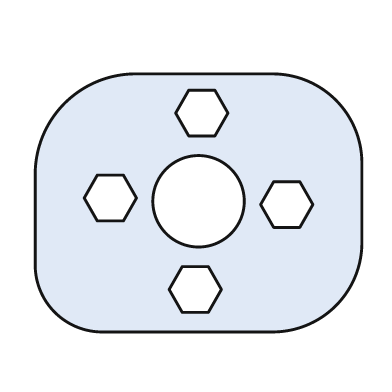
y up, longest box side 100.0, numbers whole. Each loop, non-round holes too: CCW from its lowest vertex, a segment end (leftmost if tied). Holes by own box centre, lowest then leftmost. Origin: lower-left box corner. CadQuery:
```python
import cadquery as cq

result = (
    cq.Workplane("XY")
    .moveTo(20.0, 0.0)
    .lineTo(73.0, 0.0)
    .threePointArc((92.0, 8.0), (100.0, 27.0))
    .lineTo(100.0, 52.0)
    .threePointArc((92.0, 71.0), (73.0, 79.0))
    .lineTo(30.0, 79.0)
    .threePointArc((9.0, 70.0), (0.0, 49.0))
    .lineTo(0.0, 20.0)
    .threePointArc((6.0, 6.0), (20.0, 0.0))
    .close()
    .moveTo(45.0, 6.0)
    .lineTo(53.0, 6.0)
    .lineTo(57.0, 13.0)
    .lineTo(53.0, 20.0)
    .lineTo(45.0, 20.0)
    .lineTo(41.0, 13.0)
    .close()
    .moveTo(73.0, 32.0)
    .lineTo(81.0, 32.0)
    .lineTo(85.0, 39.0)
    .lineTo(81.0, 46.0)
    .lineTo(73.0, 46.0)
    .lineTo(69.0, 39.0)
    .close()
    .moveTo(50.0, 40.0)
    .circle(14.0)
    .moveTo(19.0, 34.0)
    .lineTo(27.0, 34.0)
    .lineTo(31.0, 41.0)
    .lineTo(27.0, 48.0)
    .lineTo(19.0, 48.0)
    .lineTo(15.0, 41.0)
    .close()
    .moveTo(47.0, 60.0)
    .lineTo(55.0, 60.0)
    .lineTo(59.0, 67.0)
    .lineTo(55.0, 74.0)
    .lineTo(47.0, 74.0)
    .lineTo(43.0, 67.0)
    .close()
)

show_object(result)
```